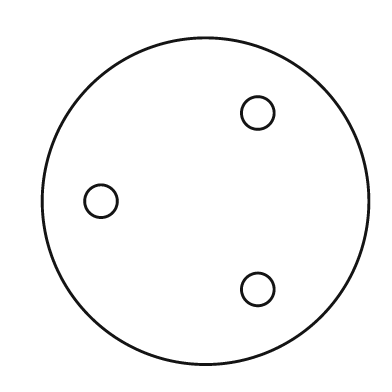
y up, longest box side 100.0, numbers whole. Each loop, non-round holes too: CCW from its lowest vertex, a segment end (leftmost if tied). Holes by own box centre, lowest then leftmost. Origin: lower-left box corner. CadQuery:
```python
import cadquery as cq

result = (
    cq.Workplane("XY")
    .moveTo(50.0, 50.0)
    .circle(50.0)
    .moveTo(66.0, 23.0)
    .circle(5.0)
    .moveTo(18.0, 50.0)
    .circle(5.0)
    .moveTo(66.0, 77.0)
    .circle(5.0)
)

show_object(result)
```